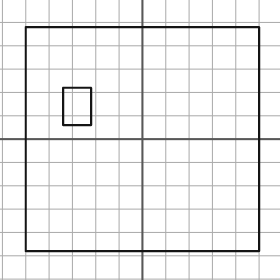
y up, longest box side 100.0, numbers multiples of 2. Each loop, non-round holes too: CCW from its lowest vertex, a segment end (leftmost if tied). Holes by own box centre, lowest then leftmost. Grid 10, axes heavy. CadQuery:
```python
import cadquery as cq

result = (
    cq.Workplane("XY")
    .moveTo(-50.0, -48.0)
    .lineTo(50.0, -48.0)
    .lineTo(50.0, 48.0)
    .lineTo(-50.0, 48.0)
    .close()
    .moveTo(-34.0, 6.0)
    .lineTo(-22.0, 6.0)
    .lineTo(-22.0, 22.0)
    .lineTo(-34.0, 22.0)
    .close()
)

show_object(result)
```